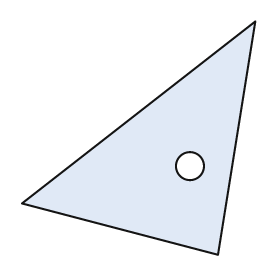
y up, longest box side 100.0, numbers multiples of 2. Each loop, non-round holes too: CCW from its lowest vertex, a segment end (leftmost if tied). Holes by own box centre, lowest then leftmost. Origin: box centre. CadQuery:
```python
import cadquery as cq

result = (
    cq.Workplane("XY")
    .moveTo(34.0, -50.0)
    .lineTo(50.0, 50.0)
    .lineTo(-50.0, -28.0)
    .close()
    .moveTo(22.0, -12.0)
    .circle(6.0)
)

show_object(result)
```